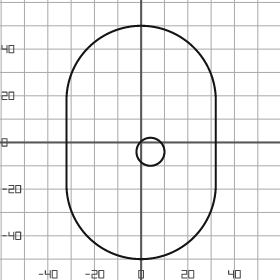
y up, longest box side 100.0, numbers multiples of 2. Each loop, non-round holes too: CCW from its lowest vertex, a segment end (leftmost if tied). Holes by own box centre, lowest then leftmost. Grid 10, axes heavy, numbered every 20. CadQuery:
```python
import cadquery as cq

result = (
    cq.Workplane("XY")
    .moveTo(-32.0, -18.0)
    .threePointArc((0.0, -50.0), (32.0, -18.0))
    .lineTo(32.0, 18.0)
    .threePointArc((0.0, 50.0), (-32.0, 18.0))
    .close()
    .moveTo(4.0, -4.0)
    .circle(6.0)
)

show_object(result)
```